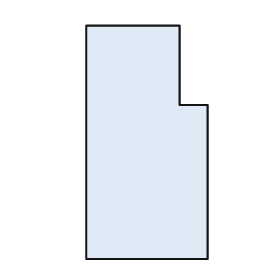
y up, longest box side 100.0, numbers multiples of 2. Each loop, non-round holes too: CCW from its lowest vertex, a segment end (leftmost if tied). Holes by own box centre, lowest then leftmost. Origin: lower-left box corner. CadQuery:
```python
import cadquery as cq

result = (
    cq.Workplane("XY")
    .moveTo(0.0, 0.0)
    .lineTo(52.0, 0.0)
    .lineTo(52.0, 66.0)
    .lineTo(40.0, 66.0)
    .lineTo(40.0, 100.0)
    .lineTo(0.0, 100.0)
    .close()
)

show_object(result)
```